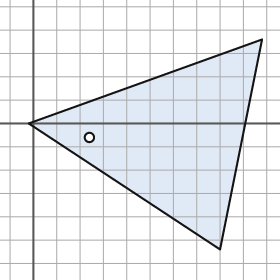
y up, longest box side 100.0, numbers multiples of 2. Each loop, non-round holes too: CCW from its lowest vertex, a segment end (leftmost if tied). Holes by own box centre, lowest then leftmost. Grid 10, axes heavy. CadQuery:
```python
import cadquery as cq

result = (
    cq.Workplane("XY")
    .moveTo(80.0, -54.0)
    .lineTo(98.0, 36.0)
    .lineTo(-2.0, 0.0)
    .close()
    .moveTo(24.0, -6.0)
    .circle(2.0)
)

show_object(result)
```